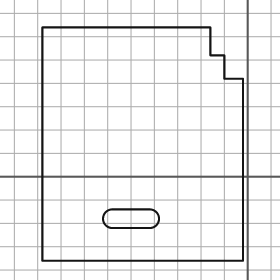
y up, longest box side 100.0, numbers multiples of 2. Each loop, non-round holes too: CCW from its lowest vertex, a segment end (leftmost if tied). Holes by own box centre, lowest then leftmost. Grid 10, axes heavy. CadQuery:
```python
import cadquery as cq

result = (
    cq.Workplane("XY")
    .moveTo(-88.0, -36.0)
    .lineTo(-2.0, -36.0)
    .lineTo(-2.0, 42.0)
    .lineTo(-10.0, 42.0)
    .lineTo(-10.0, 52.0)
    .lineTo(-16.0, 52.0)
    .lineTo(-16.0, 64.0)
    .lineTo(-88.0, 64.0)
    .close()
    .moveTo(-58.0, -22.0)
    .lineTo(-42.0, -22.0)
    .threePointArc((-38.0, -18.0), (-42.0, -14.0))
    .lineTo(-58.0, -14.0)
    .threePointArc((-62.0, -18.0), (-58.0, -22.0))
    .close()
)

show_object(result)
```